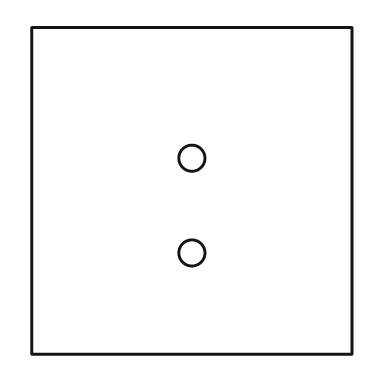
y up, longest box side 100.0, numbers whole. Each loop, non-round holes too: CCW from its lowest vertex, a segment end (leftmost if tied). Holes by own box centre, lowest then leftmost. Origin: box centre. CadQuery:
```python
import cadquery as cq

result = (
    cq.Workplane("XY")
    .moveTo(-49.0, -50.0)
    .lineTo(49.0, -50.0)
    .lineTo(49.0, 50.0)
    .lineTo(-49.0, 50.0)
    .close()
    .moveTo(0.0, -19.0)
    .circle(4.0)
    .moveTo(0.0, 10.0)
    .circle(4.0)
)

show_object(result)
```